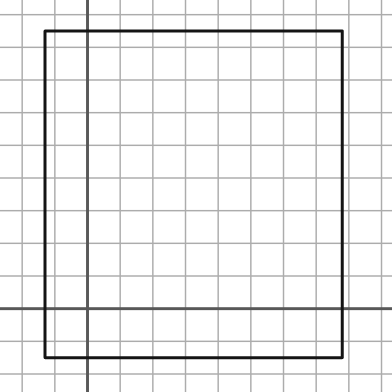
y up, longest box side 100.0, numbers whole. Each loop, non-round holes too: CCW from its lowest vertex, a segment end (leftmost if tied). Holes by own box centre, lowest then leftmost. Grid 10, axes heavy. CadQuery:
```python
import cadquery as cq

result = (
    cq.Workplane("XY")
    .moveTo(-13.0, -15.0)
    .lineTo(78.0, -15.0)
    .lineTo(78.0, 85.0)
    .lineTo(-13.0, 85.0)
    .close()
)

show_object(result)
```